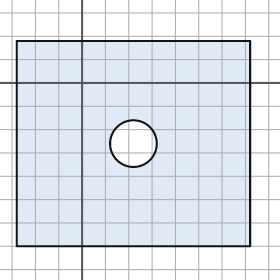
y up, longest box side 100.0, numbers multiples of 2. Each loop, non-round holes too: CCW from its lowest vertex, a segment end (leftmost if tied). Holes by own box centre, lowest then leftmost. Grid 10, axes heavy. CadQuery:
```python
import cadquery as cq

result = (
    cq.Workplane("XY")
    .moveTo(-28.0, -70.0)
    .lineTo(72.0, -70.0)
    .lineTo(72.0, 18.0)
    .lineTo(-28.0, 18.0)
    .close()
    .moveTo(22.0, -26.0)
    .circle(10.0)
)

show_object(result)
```